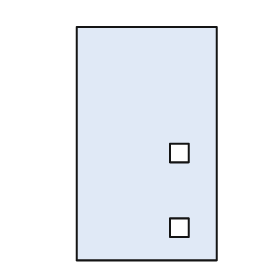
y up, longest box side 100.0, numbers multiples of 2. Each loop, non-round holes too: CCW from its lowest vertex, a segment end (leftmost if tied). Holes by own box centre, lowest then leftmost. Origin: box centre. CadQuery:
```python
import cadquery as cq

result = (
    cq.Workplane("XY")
    .moveTo(-30.0, -50.0)
    .lineTo(30.0, -50.0)
    .lineTo(30.0, 50.0)
    .lineTo(-30.0, 50.0)
    .close()
    .moveTo(10.0, -40.0)
    .lineTo(18.0, -40.0)
    .lineTo(18.0, -32.0)
    .lineTo(10.0, -32.0)
    .close()
    .moveTo(10.0, -8.0)
    .lineTo(18.0, -8.0)
    .lineTo(18.0, 0.0)
    .lineTo(10.0, 0.0)
    .close()
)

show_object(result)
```